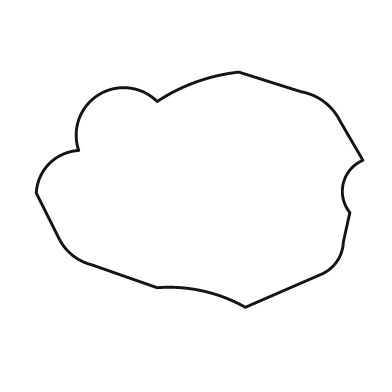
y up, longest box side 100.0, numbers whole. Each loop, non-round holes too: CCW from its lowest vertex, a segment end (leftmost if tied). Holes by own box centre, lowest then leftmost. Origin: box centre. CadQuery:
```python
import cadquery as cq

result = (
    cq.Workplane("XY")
    .moveTo(14.0, -36.0)
    .lineTo(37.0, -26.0)
    .threePointArc((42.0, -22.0), (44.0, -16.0))
    .lineTo(46.0, -7.0)
    .threePointArc((44.0, 2.0), (50.0, 9.0))
    .lineTo(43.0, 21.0)
    .threePointArc((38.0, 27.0), (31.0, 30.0))
    .lineTo(12.0, 36.0)
    .threePointArc((-1.0, 33.0), (-13.0, 27.0))
    .threePointArc((-31.0, 29.0), (-37.0, 12.0))
    .threePointArc((-46.0, 8.0), (-50.0, -1.0))
    .lineTo(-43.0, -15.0)
    .threePointArc((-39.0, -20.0), (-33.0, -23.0))
    .lineTo(-13.0, -30.0)
    .threePointArc((1.0, -31.0), (14.0, -36.0))
    .close()
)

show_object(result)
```